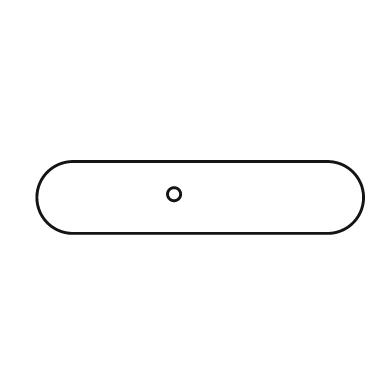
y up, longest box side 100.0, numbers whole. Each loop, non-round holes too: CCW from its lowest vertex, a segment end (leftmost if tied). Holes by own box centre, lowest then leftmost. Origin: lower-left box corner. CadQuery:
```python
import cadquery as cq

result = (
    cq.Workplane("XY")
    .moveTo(11.0, 0.0)
    .lineTo(89.0, 0.0)
    .threePointArc((100.0, 11.0), (89.0, 22.0))
    .lineTo(11.0, 22.0)
    .threePointArc((0.0, 11.0), (11.0, 0.0))
    .close()
    .moveTo(42.0, 12.0)
    .circle(2.0)
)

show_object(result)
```